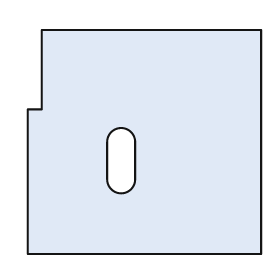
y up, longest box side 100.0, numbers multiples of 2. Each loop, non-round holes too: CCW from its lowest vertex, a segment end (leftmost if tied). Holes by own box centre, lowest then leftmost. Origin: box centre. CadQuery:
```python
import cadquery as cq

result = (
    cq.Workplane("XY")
    .moveTo(-50.0, -48.0)
    .lineTo(50.0, -48.0)
    .lineTo(50.0, 48.0)
    .lineTo(-44.0, 48.0)
    .lineTo(-44.0, 14.0)
    .lineTo(-50.0, 14.0)
    .close()
    .moveTo(-16.0, -16.0)
    .threePointArc((-10.0, -22.0), (-4.0, -16.0))
    .lineTo(-4.0, 0.0)
    .threePointArc((-10.0, 6.0), (-16.0, 0.0))
    .close()
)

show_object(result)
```